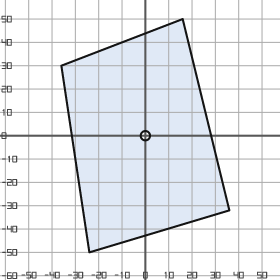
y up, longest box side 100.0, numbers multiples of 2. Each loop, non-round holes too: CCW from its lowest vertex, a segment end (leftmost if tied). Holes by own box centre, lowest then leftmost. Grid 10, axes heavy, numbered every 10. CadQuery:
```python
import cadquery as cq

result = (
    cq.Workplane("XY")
    .moveTo(-24.0, -50.0)
    .lineTo(36.0, -32.0)
    .lineTo(16.0, 50.0)
    .lineTo(-36.0, 30.0)
    .close()
    .moveTo(0.0, 0.0)
    .circle(2.0)
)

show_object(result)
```